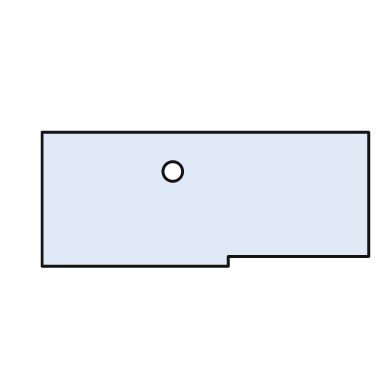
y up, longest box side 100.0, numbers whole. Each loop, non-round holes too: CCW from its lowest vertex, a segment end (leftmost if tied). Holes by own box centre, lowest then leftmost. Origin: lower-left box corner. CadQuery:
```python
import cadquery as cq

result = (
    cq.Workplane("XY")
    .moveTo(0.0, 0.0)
    .lineTo(57.0, 0.0)
    .lineTo(57.0, 3.0)
    .lineTo(100.0, 3.0)
    .lineTo(100.0, 41.0)
    .lineTo(0.0, 41.0)
    .close()
    .moveTo(40.0, 29.0)
    .circle(3.0)
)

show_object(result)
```